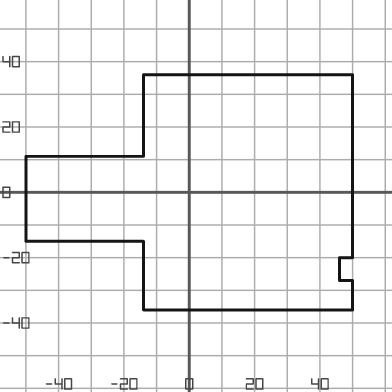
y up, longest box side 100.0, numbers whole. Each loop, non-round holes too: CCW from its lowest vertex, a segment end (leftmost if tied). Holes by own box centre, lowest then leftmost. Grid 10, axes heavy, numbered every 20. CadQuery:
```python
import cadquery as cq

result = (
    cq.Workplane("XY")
    .moveTo(-14.0, -36.0)
    .lineTo(50.0, -36.0)
    .lineTo(50.0, -27.0)
    .lineTo(46.0, -27.0)
    .lineTo(46.0, -20.0)
    .lineTo(50.0, -20.0)
    .lineTo(50.0, 36.0)
    .lineTo(-14.0, 36.0)
    .lineTo(-14.0, 11.0)
    .lineTo(-50.0, 11.0)
    .lineTo(-50.0, -15.0)
    .lineTo(-14.0, -15.0)
    .close()
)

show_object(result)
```